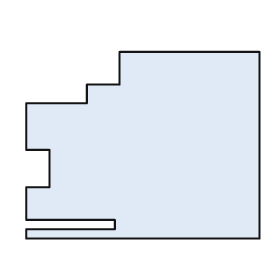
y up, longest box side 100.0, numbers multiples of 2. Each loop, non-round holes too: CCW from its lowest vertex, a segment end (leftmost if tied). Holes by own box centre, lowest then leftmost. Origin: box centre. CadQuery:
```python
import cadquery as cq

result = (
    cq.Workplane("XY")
    .moveTo(-50.0, -40.0)
    .lineTo(50.0, -40.0)
    .lineTo(50.0, 40.0)
    .lineTo(-10.0, 40.0)
    .lineTo(-10.0, 26.0)
    .lineTo(-24.0, 26.0)
    .lineTo(-24.0, 18.0)
    .lineTo(-50.0, 18.0)
    .lineTo(-50.0, -2.0)
    .lineTo(-40.0, -2.0)
    .lineTo(-40.0, -18.0)
    .lineTo(-50.0, -18.0)
    .lineTo(-50.0, -32.0)
    .lineTo(-12.0, -32.0)
    .lineTo(-12.0, -36.0)
    .lineTo(-50.0, -36.0)
    .close()
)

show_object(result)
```